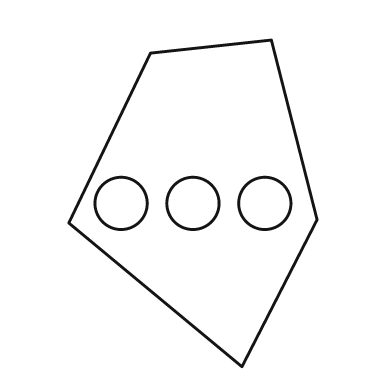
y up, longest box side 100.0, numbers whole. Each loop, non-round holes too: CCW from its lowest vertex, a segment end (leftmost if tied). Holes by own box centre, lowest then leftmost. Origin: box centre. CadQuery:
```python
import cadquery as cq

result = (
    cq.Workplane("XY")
    .moveTo(15.0, -50.0)
    .lineTo(38.0, -5.0)
    .lineTo(24.0, 50.0)
    .lineTo(-13.0, 46.0)
    .lineTo(-38.0, -6.0)
    .close()
    .moveTo(-22.0, 0.0)
    .circle(8.0)
    .moveTo(0.0, 0.0)
    .circle(8.0)
    .moveTo(22.0, 0.0)
    .circle(8.0)
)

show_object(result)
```